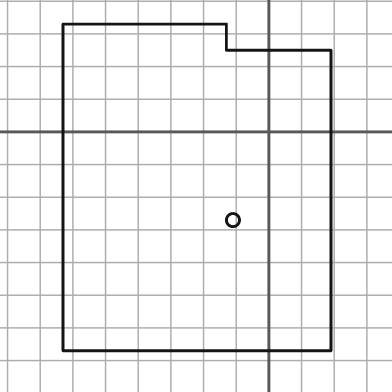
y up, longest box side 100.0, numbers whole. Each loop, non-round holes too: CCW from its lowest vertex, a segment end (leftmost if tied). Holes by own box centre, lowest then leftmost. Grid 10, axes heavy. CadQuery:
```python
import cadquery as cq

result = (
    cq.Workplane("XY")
    .moveTo(-63.0, -67.0)
    .lineTo(19.0, -67.0)
    .lineTo(19.0, 25.0)
    .lineTo(-13.0, 25.0)
    .lineTo(-13.0, 33.0)
    .lineTo(-63.0, 33.0)
    .close()
    .moveTo(-11.0, -27.0)
    .circle(2.0)
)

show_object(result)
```